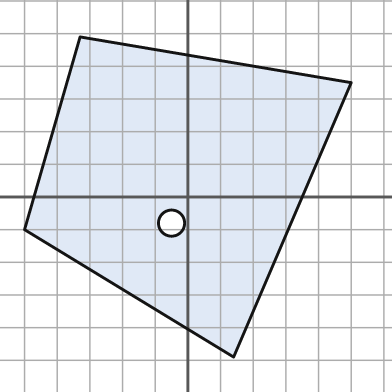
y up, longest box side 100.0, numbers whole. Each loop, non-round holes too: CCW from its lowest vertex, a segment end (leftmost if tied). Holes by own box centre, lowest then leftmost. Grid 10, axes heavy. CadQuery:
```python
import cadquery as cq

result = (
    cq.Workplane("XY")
    .moveTo(14.0, -49.0)
    .lineTo(50.0, 35.0)
    .lineTo(-33.0, 49.0)
    .lineTo(-50.0, -10.0)
    .close()
    .moveTo(-5.0, -8.0)
    .circle(4.0)
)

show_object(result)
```